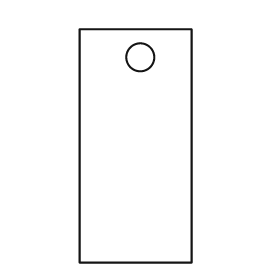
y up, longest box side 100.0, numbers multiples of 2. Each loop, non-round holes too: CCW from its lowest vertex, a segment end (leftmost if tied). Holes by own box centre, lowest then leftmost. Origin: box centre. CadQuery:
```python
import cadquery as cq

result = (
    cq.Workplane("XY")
    .moveTo(-24.0, -50.0)
    .lineTo(24.0, -50.0)
    .lineTo(24.0, 50.0)
    .lineTo(-24.0, 50.0)
    .close()
    .moveTo(2.0, 38.0)
    .circle(6.0)
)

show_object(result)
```